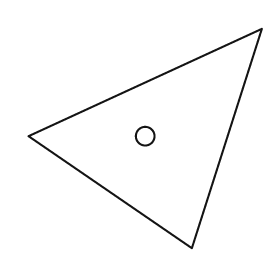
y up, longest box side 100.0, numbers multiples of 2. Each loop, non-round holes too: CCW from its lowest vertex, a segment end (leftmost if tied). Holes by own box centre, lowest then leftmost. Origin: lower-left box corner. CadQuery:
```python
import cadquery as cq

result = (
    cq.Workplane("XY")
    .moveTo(70.0, 0.0)
    .lineTo(100.0, 94.0)
    .lineTo(0.0, 48.0)
    .close()
    .moveTo(50.0, 48.0)
    .circle(4.0)
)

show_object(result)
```